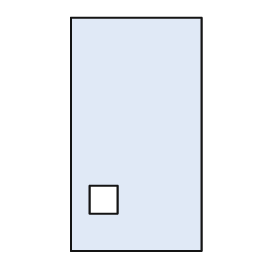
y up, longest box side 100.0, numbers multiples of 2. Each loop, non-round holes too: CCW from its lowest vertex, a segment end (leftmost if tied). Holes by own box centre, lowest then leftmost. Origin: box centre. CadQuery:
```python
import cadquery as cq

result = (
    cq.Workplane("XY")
    .moveTo(-28.0, -50.0)
    .lineTo(28.0, -50.0)
    .lineTo(28.0, 50.0)
    .lineTo(-28.0, 50.0)
    .close()
    .moveTo(-20.0, -34.0)
    .lineTo(-8.0, -34.0)
    .lineTo(-8.0, -22.0)
    .lineTo(-20.0, -22.0)
    .close()
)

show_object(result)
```